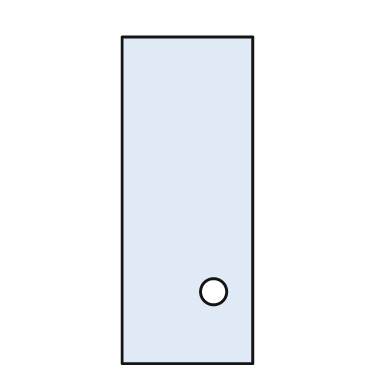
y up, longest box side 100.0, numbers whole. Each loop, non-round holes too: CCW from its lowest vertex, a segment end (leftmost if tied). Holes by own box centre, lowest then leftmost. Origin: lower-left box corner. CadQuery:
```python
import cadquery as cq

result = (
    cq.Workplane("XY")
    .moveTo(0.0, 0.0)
    .lineTo(40.0, 0.0)
    .lineTo(40.0, 100.0)
    .lineTo(0.0, 100.0)
    .close()
    .moveTo(28.0, 22.0)
    .circle(4.0)
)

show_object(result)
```